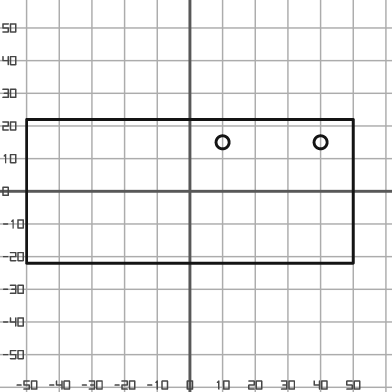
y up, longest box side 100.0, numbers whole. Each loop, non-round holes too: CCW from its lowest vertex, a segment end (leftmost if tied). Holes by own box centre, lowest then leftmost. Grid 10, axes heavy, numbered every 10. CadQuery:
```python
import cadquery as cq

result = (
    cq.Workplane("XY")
    .moveTo(-50.0, -22.0)
    .lineTo(50.0, -22.0)
    .lineTo(50.0, 22.0)
    .lineTo(-50.0, 22.0)
    .close()
    .moveTo(10.0, 15.0)
    .circle(2.0)
    .moveTo(40.0, 15.0)
    .circle(2.0)
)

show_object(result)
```